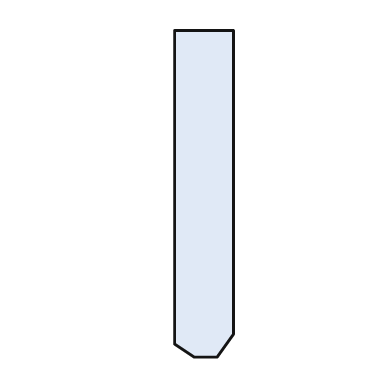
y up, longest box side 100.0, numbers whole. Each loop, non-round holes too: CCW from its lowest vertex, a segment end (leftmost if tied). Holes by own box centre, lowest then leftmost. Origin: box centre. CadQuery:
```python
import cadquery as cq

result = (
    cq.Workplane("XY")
    .moveTo(-3.0, -50.0)
    .lineTo(4.0, -50.0)
    .lineTo(9.0, -43.0)
    .lineTo(9.0, 50.0)
    .lineTo(-9.0, 50.0)
    .lineTo(-9.0, -46.0)
    .close()
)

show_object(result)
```